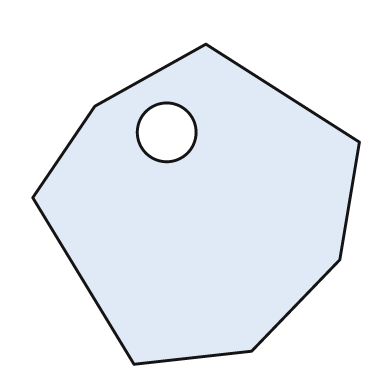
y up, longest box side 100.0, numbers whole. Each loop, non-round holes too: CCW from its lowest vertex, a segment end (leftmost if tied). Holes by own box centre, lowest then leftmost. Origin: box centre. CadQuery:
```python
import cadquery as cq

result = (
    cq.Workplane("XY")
    .moveTo(-19.0, -49.0)
    .lineTo(17.0, -45.0)
    .lineTo(44.0, -17.0)
    .lineTo(50.0, 19.0)
    .lineTo(3.0, 49.0)
    .lineTo(-31.0, 30.0)
    .lineTo(-50.0, 2.0)
    .close()
    .moveTo(-9.0, 22.0)
    .circle(9.0)
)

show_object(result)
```